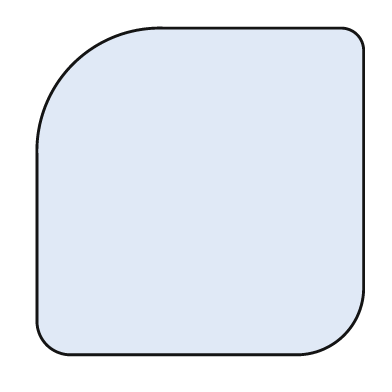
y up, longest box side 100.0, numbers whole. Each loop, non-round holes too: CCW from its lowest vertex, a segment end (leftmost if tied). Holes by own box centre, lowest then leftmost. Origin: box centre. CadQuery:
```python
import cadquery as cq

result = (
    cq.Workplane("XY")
    .moveTo(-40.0, -50.0)
    .lineTo(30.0, -50.0)
    .threePointArc((44.0, -44.0), (50.0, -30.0))
    .lineTo(50.0, 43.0)
    .threePointArc((48.0, 48.0), (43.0, 50.0))
    .lineTo(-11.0, 50.0)
    .threePointArc((-39.0, 39.0), (-50.0, 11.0))
    .lineTo(-50.0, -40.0)
    .threePointArc((-47.0, -47.0), (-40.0, -50.0))
    .close()
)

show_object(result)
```